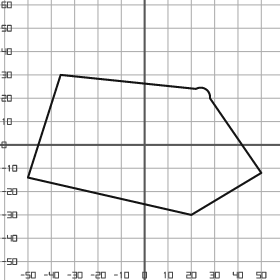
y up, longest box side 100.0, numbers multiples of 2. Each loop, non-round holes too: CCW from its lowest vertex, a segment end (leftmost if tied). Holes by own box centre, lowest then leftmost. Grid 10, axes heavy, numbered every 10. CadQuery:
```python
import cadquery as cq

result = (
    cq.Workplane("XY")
    .moveTo(20.0, -30.0)
    .lineTo(50.0, -12.0)
    .lineTo(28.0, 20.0)
    .threePointArc((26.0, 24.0), (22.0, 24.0))
    .lineTo(-36.0, 30.0)
    .lineTo(-50.0, -14.0)
    .close()
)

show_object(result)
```